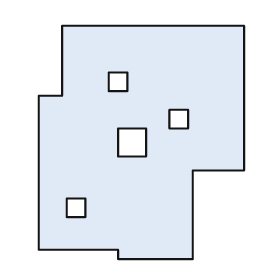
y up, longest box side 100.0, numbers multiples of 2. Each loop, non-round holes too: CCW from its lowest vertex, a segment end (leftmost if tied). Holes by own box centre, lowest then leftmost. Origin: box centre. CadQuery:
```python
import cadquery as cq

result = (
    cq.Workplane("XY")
    .moveTo(-10.0, -50.0)
    .lineTo(22.0, -50.0)
    .lineTo(22.0, -12.0)
    .lineTo(44.0, -12.0)
    .lineTo(44.0, 50.0)
    .lineTo(-34.0, 50.0)
    .lineTo(-34.0, 20.0)
    .lineTo(-44.0, 20.0)
    .lineTo(-44.0, -46.0)
    .lineTo(-10.0, -46.0)
    .close()
    .moveTo(-32.0, -32.0)
    .lineTo(-24.0, -32.0)
    .lineTo(-24.0, -24.0)
    .lineTo(-32.0, -24.0)
    .close()
    .moveTo(-10.0, -6.0)
    .lineTo(2.0, -6.0)
    .lineTo(2.0, 6.0)
    .lineTo(-10.0, 6.0)
    .close()
    .moveTo(12.0, 6.0)
    .lineTo(20.0, 6.0)
    .lineTo(20.0, 14.0)
    .lineTo(12.0, 14.0)
    .close()
    .moveTo(-14.0, 22.0)
    .lineTo(-6.0, 22.0)
    .lineTo(-6.0, 30.0)
    .lineTo(-14.0, 30.0)
    .close()
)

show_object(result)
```